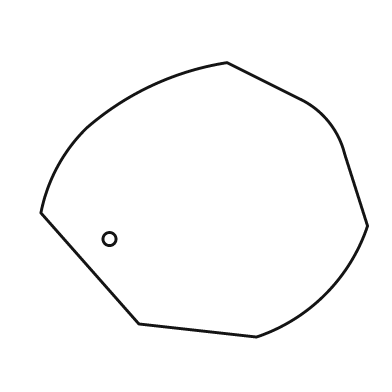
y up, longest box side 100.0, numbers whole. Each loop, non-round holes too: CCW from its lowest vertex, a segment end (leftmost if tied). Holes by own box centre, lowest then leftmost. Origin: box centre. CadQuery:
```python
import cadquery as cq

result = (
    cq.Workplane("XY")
    .moveTo(16.0, -42.0)
    .threePointArc((37.0, -29.0), (50.0, -8.0))
    .lineTo(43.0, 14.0)
    .threePointArc((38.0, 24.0), (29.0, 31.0))
    .lineTo(7.0, 42.0)
    .threePointArc((-16.0, 35.0), (-36.0, 22.0))
    .threePointArc((-45.0, 10.0), (-50.0, -4.0))
    .lineTo(-20.0, -38.0)
    .close()
    .moveTo(-29.0, -12.0)
    .circle(2.0)
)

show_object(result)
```